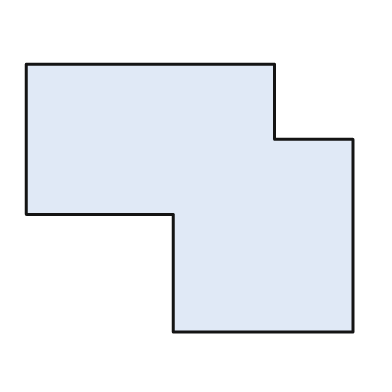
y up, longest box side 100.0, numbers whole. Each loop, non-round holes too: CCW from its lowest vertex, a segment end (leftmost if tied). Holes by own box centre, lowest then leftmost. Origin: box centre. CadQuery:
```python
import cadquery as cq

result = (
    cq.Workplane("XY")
    .moveTo(-5.0, -41.0)
    .lineTo(50.0, -41.0)
    .lineTo(50.0, 18.0)
    .lineTo(26.0, 18.0)
    .lineTo(26.0, 41.0)
    .lineTo(-50.0, 41.0)
    .lineTo(-50.0, -5.0)
    .lineTo(-5.0, -5.0)
    .close()
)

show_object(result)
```